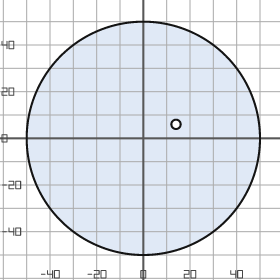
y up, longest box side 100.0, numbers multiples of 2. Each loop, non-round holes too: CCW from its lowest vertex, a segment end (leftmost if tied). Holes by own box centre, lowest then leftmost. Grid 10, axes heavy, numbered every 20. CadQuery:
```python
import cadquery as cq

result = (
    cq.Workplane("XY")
    .moveTo(0.0, 0.0)
    .circle(50.0)
    .moveTo(14.0, 6.0)
    .circle(2.0)
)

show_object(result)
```